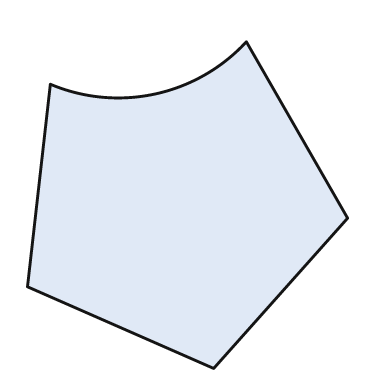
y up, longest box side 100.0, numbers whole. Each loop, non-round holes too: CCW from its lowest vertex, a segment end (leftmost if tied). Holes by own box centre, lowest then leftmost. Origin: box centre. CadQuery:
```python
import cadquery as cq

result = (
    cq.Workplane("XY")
    .moveTo(8.0, -50.0)
    .lineTo(49.0, -4.0)
    .lineTo(18.0, 50.0)
    .threePointArc((-10.0, 34.0), (-42.0, 37.0))
    .lineTo(-49.0, -25.0)
    .close()
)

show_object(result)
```